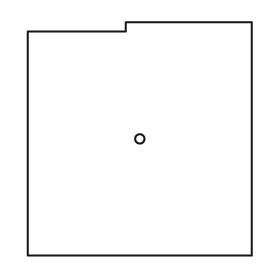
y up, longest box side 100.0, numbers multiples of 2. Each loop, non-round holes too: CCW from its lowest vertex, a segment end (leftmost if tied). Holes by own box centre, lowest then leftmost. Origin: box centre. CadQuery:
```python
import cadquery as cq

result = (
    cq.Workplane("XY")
    .moveTo(-48.0, -50.0)
    .lineTo(48.0, -50.0)
    .lineTo(48.0, 50.0)
    .lineTo(-6.0, 50.0)
    .lineTo(-6.0, 46.0)
    .lineTo(-48.0, 46.0)
    .close()
    .moveTo(0.0, 0.0)
    .circle(2.0)
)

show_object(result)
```